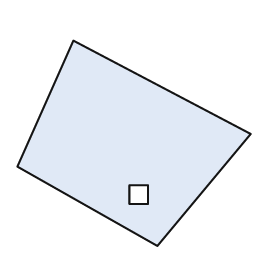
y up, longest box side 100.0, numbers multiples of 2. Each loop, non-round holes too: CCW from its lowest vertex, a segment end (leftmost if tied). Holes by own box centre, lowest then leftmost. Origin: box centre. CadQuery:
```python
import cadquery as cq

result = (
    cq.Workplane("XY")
    .moveTo(10.0, -44.0)
    .lineTo(50.0, 4.0)
    .lineTo(-26.0, 44.0)
    .lineTo(-50.0, -10.0)
    .close()
    .moveTo(-2.0, -26.0)
    .lineTo(6.0, -26.0)
    .lineTo(6.0, -18.0)
    .lineTo(-2.0, -18.0)
    .close()
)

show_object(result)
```